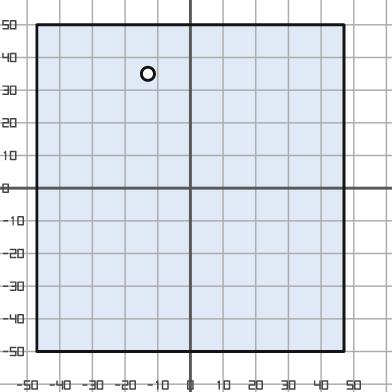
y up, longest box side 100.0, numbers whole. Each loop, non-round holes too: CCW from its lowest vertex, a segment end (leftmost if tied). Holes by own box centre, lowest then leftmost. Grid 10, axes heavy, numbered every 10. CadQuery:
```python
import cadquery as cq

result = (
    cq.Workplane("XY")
    .moveTo(-47.0, -50.0)
    .lineTo(47.0, -50.0)
    .lineTo(47.0, 50.0)
    .lineTo(-47.0, 50.0)
    .close()
    .moveTo(-13.0, 35.0)
    .circle(2.0)
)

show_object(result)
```